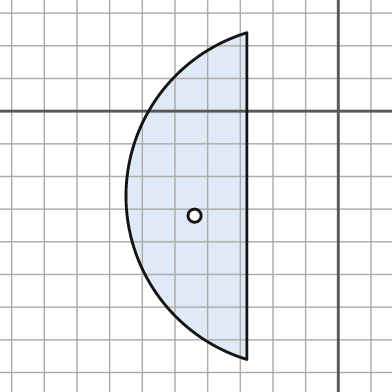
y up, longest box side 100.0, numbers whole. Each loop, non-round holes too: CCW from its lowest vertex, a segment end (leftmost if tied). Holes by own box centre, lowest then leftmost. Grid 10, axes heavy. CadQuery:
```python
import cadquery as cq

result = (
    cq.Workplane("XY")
    .moveTo(-28.0, -76.0)
    .lineTo(-28.0, 24.0)
    .threePointArc((-65.0, -26.0), (-28.0, -76.0))
    .close()
    .moveTo(-44.0, -32.0)
    .circle(2.0)
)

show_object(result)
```